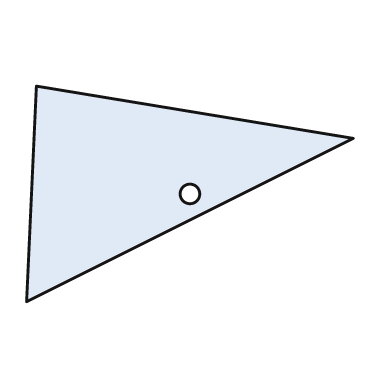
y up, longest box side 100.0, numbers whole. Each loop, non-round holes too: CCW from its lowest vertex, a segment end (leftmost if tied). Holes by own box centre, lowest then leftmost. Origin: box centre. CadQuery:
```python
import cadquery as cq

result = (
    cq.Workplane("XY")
    .moveTo(-50.0, -33.0)
    .lineTo(50.0, 17.0)
    .lineTo(-47.0, 33.0)
    .close()
    .moveTo(0.0, 0.0)
    .circle(3.0)
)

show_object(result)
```